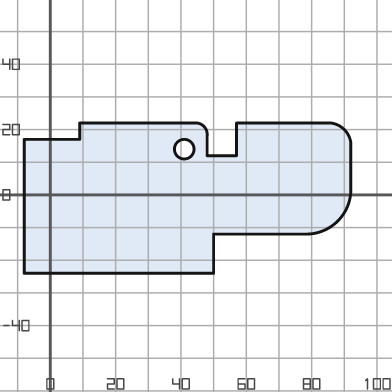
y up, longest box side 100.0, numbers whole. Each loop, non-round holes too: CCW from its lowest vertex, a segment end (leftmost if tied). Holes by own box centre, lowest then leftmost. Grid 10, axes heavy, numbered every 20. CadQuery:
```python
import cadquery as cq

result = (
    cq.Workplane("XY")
    .moveTo(-8.0, -24.0)
    .lineTo(50.0, -24.0)
    .lineTo(50.0, -12.0)
    .lineTo(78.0, -12.0)
    .threePointArc((88.0, -8.0), (92.0, 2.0))
    .lineTo(92.0, 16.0)
    .threePointArc((90.0, 20.0), (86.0, 22.0))
    .lineTo(57.0, 22.0)
    .lineTo(57.0, 12.0)
    .lineTo(48.0, 12.0)
    .lineTo(48.0, 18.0)
    .threePointArc((47.0, 21.0), (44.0, 22.0))
    .lineTo(9.0, 22.0)
    .lineTo(9.0, 17.0)
    .lineTo(-8.0, 17.0)
    .close()
    .moveTo(41.0, 14.0)
    .circle(3.0)
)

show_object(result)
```